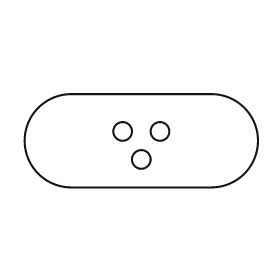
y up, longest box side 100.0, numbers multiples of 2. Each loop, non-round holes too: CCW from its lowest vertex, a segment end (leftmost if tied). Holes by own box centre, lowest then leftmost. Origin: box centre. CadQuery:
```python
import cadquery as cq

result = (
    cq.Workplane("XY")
    .moveTo(-30.0, -20.0)
    .lineTo(30.0, -20.0)
    .threePointArc((50.0, 0.0), (30.0, 20.0))
    .lineTo(-30.0, 20.0)
    .threePointArc((-50.0, 0.0), (-30.0, -20.0))
    .close()
    .moveTo(0.0, -8.0)
    .circle(4.0)
    .moveTo(-8.0, 4.0)
    .circle(4.0)
    .moveTo(8.0, 4.0)
    .circle(4.0)
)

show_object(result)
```